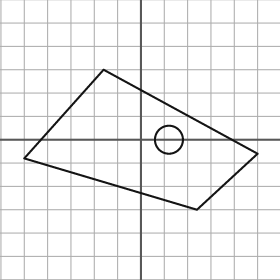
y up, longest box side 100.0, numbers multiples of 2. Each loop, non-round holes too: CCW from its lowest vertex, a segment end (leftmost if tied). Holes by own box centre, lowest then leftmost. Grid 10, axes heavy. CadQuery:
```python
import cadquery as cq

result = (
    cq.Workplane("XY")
    .moveTo(24.0, -30.0)
    .lineTo(50.0, -6.0)
    .lineTo(-16.0, 30.0)
    .lineTo(-50.0, -8.0)
    .close()
    .moveTo(12.0, 0.0)
    .circle(6.0)
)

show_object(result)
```